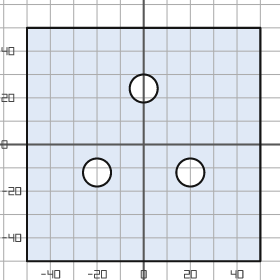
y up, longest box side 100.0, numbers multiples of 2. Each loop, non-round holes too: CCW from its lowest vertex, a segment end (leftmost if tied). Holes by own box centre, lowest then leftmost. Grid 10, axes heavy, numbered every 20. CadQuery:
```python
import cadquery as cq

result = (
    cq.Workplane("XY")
    .moveTo(-50.0, -50.0)
    .lineTo(50.0, -50.0)
    .lineTo(50.0, 50.0)
    .lineTo(-50.0, 50.0)
    .close()
    .moveTo(-20.0, -12.0)
    .circle(6.0)
    .moveTo(20.0, -12.0)
    .circle(6.0)
    .moveTo(0.0, 24.0)
    .circle(6.0)
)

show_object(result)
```